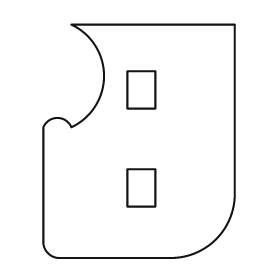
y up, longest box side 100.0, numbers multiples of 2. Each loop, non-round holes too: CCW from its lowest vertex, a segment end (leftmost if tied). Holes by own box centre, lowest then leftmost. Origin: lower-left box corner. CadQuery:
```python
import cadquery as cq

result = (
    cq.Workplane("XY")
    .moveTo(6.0, 0.0)
    .lineTo(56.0, 0.0)
    .threePointArc((74.0, 8.0), (82.0, 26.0))
    .lineTo(82.0, 100.0)
    .lineTo(12.0, 100.0)
    .threePointArc((26.0, 78.0), (12.0, 56.0))
    .threePointArc((6.0, 60.0), (0.0, 56.0))
    .lineTo(0.0, 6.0)
    .threePointArc((2.0, 2.0), (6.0, 0.0))
    .close()
    .moveTo(36.0, 22.0)
    .lineTo(48.0, 22.0)
    .lineTo(48.0, 38.0)
    .lineTo(36.0, 38.0)
    .close()
    .moveTo(36.0, 64.0)
    .lineTo(48.0, 64.0)
    .lineTo(48.0, 80.0)
    .lineTo(36.0, 80.0)
    .close()
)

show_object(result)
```